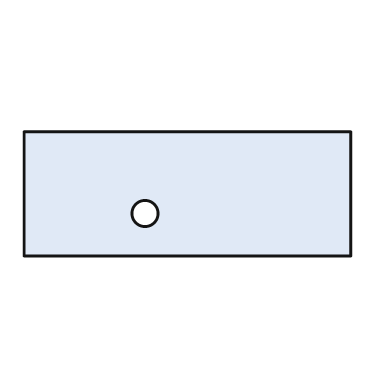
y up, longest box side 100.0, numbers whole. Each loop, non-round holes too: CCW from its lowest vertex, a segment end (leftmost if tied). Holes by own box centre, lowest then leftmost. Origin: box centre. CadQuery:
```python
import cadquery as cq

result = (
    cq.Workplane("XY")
    .moveTo(-50.0, -19.0)
    .lineTo(50.0, -19.0)
    .lineTo(50.0, 19.0)
    .lineTo(-50.0, 19.0)
    .close()
    .moveTo(-13.0, -6.0)
    .circle(4.0)
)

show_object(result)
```